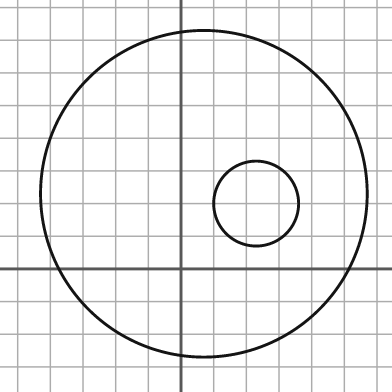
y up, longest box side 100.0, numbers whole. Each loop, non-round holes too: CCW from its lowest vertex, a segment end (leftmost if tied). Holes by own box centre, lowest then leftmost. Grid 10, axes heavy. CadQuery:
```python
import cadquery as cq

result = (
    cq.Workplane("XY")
    .moveTo(7.0, 23.0)
    .circle(50.0)
    .moveTo(23.0, 20.0)
    .circle(13.0)
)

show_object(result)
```